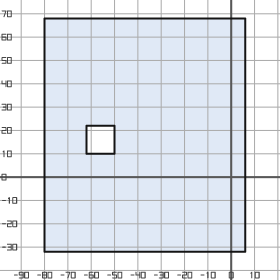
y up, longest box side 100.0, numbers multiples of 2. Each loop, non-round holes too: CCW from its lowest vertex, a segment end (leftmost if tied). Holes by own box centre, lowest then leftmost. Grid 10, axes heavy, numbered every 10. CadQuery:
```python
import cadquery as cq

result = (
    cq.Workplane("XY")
    .moveTo(-80.0, -32.0)
    .lineTo(6.0, -32.0)
    .lineTo(6.0, 68.0)
    .lineTo(-80.0, 68.0)
    .close()
    .moveTo(-62.0, 10.0)
    .lineTo(-50.0, 10.0)
    .lineTo(-50.0, 22.0)
    .lineTo(-62.0, 22.0)
    .close()
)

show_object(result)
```